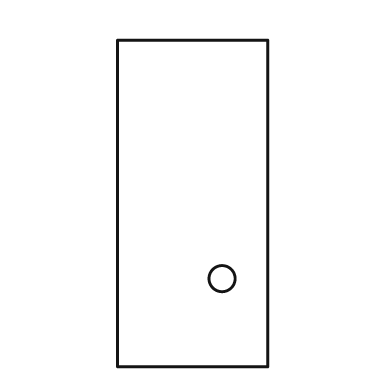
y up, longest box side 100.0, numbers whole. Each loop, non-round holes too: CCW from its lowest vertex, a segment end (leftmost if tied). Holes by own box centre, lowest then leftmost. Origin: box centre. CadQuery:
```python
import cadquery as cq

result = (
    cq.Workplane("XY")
    .moveTo(-23.0, -50.0)
    .lineTo(23.0, -50.0)
    .lineTo(23.0, 50.0)
    .lineTo(-23.0, 50.0)
    .close()
    .moveTo(9.0, -23.0)
    .circle(4.0)
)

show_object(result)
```